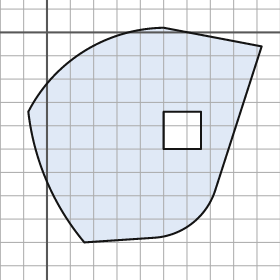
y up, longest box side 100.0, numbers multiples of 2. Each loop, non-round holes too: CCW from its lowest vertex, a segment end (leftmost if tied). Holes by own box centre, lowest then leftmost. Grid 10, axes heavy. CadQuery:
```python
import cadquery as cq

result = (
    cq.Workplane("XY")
    .moveTo(16.0, -90.0)
    .lineTo(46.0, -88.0)
    .threePointArc((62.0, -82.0), (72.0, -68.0))
    .lineTo(92.0, -6.0)
    .lineTo(50.0, 2.0)
    .threePointArc((16.0, -8.0), (-8.0, -34.0))
    .threePointArc((0.0, -64.0), (16.0, -90.0))
    .close()
    .moveTo(50.0, -50.0)
    .lineTo(66.0, -50.0)
    .lineTo(66.0, -34.0)
    .lineTo(50.0, -34.0)
    .close()
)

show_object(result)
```